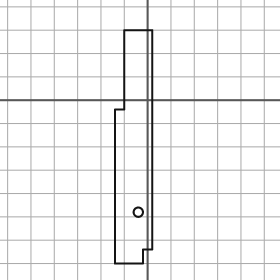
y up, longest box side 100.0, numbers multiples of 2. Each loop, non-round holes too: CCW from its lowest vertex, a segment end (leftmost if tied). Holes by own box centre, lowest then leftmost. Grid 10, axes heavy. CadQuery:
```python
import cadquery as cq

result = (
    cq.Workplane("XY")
    .moveTo(-14.0, -70.0)
    .lineTo(-2.0, -70.0)
    .lineTo(-2.0, -64.0)
    .lineTo(2.0, -64.0)
    .lineTo(2.0, 30.0)
    .lineTo(-10.0, 30.0)
    .lineTo(-10.0, -4.0)
    .lineTo(-14.0, -4.0)
    .close()
    .moveTo(-4.0, -48.0)
    .circle(2.0)
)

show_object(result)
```